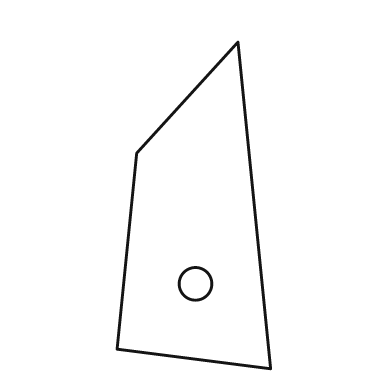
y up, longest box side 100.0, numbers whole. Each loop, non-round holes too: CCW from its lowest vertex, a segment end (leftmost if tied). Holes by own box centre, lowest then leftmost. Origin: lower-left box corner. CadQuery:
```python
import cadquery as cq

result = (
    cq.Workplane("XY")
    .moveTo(47.0, 0.0)
    .lineTo(37.0, 100.0)
    .lineTo(6.0, 66.0)
    .lineTo(0.0, 6.0)
    .close()
    .moveTo(24.0, 26.0)
    .circle(5.0)
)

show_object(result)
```